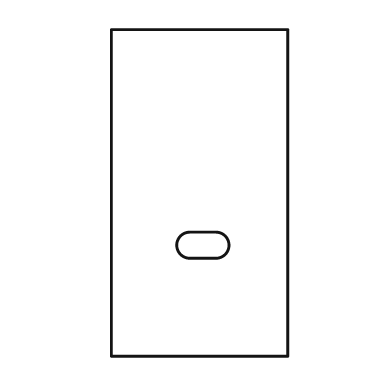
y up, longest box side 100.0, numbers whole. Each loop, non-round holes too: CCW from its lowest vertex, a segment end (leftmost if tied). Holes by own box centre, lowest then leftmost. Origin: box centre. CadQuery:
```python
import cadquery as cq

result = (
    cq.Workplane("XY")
    .moveTo(-27.0, -50.0)
    .lineTo(27.0, -50.0)
    .lineTo(27.0, 50.0)
    .lineTo(-27.0, 50.0)
    .close()
    .moveTo(-3.0, -20.0)
    .lineTo(5.0, -20.0)
    .threePointArc((9.0, -16.0), (5.0, -12.0))
    .lineTo(-3.0, -12.0)
    .threePointArc((-7.0, -16.0), (-3.0, -20.0))
    .close()
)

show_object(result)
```